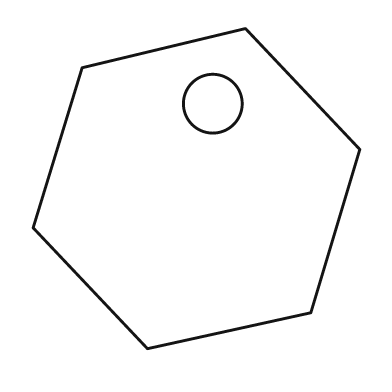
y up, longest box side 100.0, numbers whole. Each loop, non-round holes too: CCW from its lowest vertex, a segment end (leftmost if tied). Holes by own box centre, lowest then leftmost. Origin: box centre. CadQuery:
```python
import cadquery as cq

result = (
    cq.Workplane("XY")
    .moveTo(-15.0, -49.0)
    .lineTo(35.0, -38.0)
    .lineTo(50.0, 12.0)
    .lineTo(15.0, 49.0)
    .lineTo(-35.0, 37.0)
    .lineTo(-50.0, -12.0)
    .close()
    .moveTo(5.0, 26.0)
    .circle(9.0)
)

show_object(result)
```